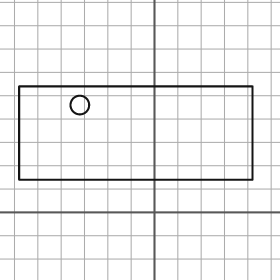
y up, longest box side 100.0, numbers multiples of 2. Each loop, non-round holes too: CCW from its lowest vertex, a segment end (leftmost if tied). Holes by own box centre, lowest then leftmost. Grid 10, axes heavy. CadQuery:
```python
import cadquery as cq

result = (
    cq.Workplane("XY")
    .moveTo(-58.0, 14.0)
    .lineTo(42.0, 14.0)
    .lineTo(42.0, 54.0)
    .lineTo(-58.0, 54.0)
    .close()
    .moveTo(-32.0, 46.0)
    .circle(4.0)
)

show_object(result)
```